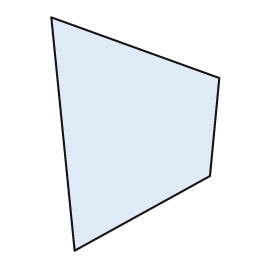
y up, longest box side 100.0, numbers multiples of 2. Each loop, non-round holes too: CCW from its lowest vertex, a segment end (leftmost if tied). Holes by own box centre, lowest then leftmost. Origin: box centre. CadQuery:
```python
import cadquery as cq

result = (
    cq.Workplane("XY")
    .moveTo(-26.0, -50.0)
    .lineTo(32.0, -18.0)
    .lineTo(36.0, 24.0)
    .lineTo(-36.0, 50.0)
    .close()
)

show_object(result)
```